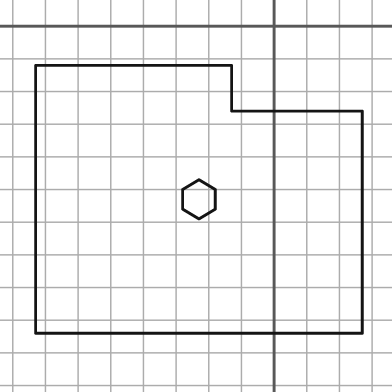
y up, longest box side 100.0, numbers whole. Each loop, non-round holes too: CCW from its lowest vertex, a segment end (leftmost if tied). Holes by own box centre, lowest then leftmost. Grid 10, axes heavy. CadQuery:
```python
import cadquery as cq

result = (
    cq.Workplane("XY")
    .moveTo(-73.0, -94.0)
    .lineTo(27.0, -94.0)
    .lineTo(27.0, -26.0)
    .lineTo(-13.0, -26.0)
    .lineTo(-13.0, -12.0)
    .lineTo(-73.0, -12.0)
    .close()
    .moveTo(-23.0, -59.0)
    .lineTo(-18.0, -56.0)
    .lineTo(-18.0, -50.0)
    .lineTo(-23.0, -47.0)
    .lineTo(-28.0, -50.0)
    .lineTo(-28.0, -56.0)
    .close()
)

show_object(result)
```